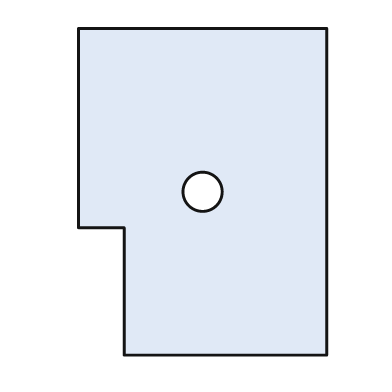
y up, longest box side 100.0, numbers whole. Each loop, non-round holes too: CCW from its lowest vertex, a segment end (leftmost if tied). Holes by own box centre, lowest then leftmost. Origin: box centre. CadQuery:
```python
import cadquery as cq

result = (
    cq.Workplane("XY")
    .moveTo(-24.0, -50.0)
    .lineTo(38.0, -50.0)
    .lineTo(38.0, 50.0)
    .lineTo(-38.0, 50.0)
    .lineTo(-38.0, -11.0)
    .lineTo(-24.0, -11.0)
    .close()
    .moveTo(0.0, 0.0)
    .circle(6.0)
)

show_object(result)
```